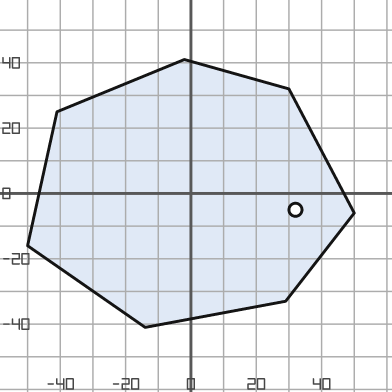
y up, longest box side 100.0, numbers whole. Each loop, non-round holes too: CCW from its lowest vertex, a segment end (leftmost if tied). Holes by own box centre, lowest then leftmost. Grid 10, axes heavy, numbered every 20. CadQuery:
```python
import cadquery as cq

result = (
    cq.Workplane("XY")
    .moveTo(-14.0, -41.0)
    .lineTo(29.0, -33.0)
    .lineTo(50.0, -6.0)
    .lineTo(30.0, 32.0)
    .lineTo(-2.0, 41.0)
    .lineTo(-41.0, 25.0)
    .lineTo(-50.0, -16.0)
    .close()
    .moveTo(32.0, -5.0)
    .circle(2.0)
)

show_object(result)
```